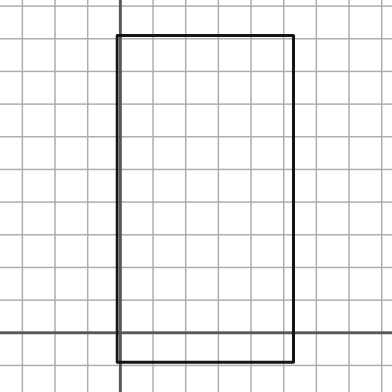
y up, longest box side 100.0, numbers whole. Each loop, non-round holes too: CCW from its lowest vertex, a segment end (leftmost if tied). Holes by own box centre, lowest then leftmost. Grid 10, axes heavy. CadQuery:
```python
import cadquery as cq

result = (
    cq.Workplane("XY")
    .moveTo(-1.0, -9.0)
    .lineTo(53.0, -9.0)
    .lineTo(53.0, 91.0)
    .lineTo(-1.0, 91.0)
    .close()
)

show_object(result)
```